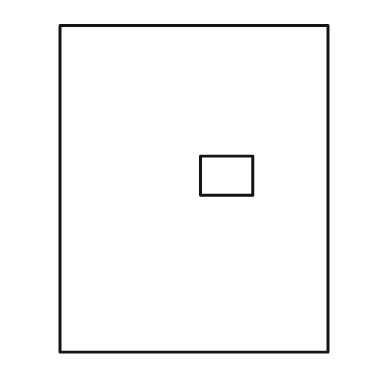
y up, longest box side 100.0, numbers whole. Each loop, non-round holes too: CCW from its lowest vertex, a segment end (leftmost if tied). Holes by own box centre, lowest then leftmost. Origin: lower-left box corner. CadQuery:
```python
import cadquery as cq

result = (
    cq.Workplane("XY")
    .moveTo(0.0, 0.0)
    .lineTo(82.0, 0.0)
    .lineTo(82.0, 100.0)
    .lineTo(0.0, 100.0)
    .close()
    .moveTo(43.0, 48.0)
    .lineTo(59.0, 48.0)
    .lineTo(59.0, 60.0)
    .lineTo(43.0, 60.0)
    .close()
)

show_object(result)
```